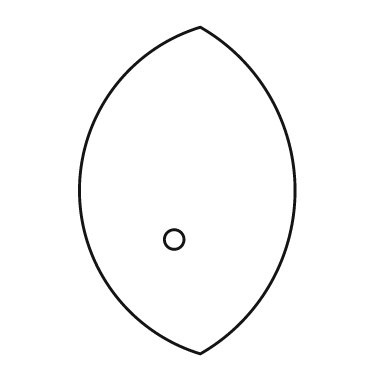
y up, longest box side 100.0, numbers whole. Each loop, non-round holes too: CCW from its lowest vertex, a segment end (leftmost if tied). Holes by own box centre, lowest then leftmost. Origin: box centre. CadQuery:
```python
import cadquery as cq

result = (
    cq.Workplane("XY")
    .moveTo(4.0, -50.0)
    .threePointArc((33.0, 0.0), (4.0, 50.0))
    .threePointArc((-33.0, 0.0), (4.0, -50.0))
    .close()
    .moveTo(-4.0, -15.0)
    .circle(3.0)
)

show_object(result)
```